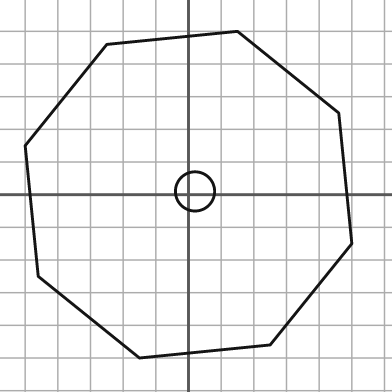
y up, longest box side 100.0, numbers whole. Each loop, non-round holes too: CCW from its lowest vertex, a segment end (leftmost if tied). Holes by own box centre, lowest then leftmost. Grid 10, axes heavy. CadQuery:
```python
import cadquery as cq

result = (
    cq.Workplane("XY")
    .moveTo(-15.0, -50.0)
    .lineTo(25.0, -46.0)
    .lineTo(50.0, -15.0)
    .lineTo(46.0, 25.0)
    .lineTo(15.0, 50.0)
    .lineTo(-25.0, 46.0)
    .lineTo(-50.0, 15.0)
    .lineTo(-46.0, -25.0)
    .close()
    .moveTo(2.0, 1.0)
    .circle(6.0)
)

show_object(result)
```